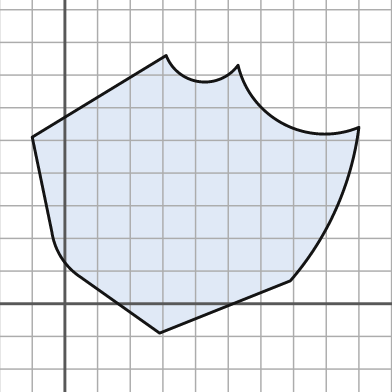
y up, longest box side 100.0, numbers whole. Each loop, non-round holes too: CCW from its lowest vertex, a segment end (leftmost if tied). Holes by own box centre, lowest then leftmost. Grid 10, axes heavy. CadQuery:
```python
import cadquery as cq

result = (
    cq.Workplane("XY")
    .moveTo(29.0, -9.0)
    .lineTo(69.0, 7.0)
    .threePointArc((83.0, 29.0), (90.0, 54.0))
    .threePointArc((67.0, 55.0), (53.0, 73.0))
    .threePointArc((41.0, 68.0), (31.0, 76.0))
    .lineTo(-10.0, 51.0)
    .lineTo(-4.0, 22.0)
    .threePointArc((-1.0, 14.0), (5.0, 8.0))
    .close()
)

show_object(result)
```